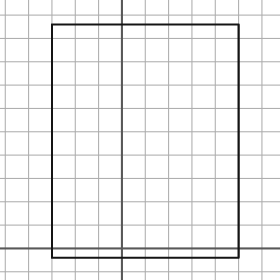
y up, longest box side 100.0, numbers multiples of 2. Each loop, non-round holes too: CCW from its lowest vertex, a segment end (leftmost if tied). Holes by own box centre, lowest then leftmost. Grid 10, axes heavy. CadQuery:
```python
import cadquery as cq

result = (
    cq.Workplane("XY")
    .moveTo(-30.0, -4.0)
    .lineTo(50.0, -4.0)
    .lineTo(50.0, 96.0)
    .lineTo(-30.0, 96.0)
    .close()
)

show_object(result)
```